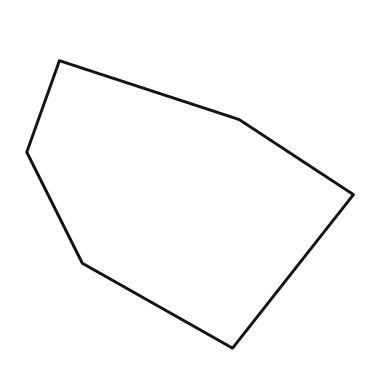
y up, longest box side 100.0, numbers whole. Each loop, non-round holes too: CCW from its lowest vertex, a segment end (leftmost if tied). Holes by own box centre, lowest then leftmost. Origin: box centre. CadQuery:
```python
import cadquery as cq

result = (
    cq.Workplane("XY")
    .moveTo(13.0, -44.0)
    .lineTo(50.0, 3.0)
    .lineTo(15.0, 26.0)
    .lineTo(-40.0, 44.0)
    .lineTo(-50.0, 16.0)
    .lineTo(-33.0, -18.0)
    .close()
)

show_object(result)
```